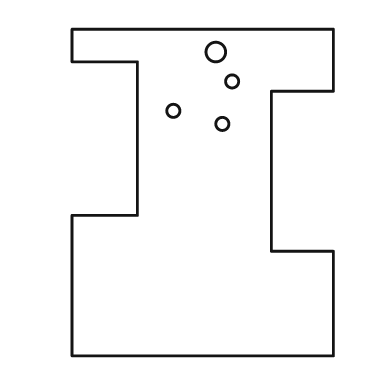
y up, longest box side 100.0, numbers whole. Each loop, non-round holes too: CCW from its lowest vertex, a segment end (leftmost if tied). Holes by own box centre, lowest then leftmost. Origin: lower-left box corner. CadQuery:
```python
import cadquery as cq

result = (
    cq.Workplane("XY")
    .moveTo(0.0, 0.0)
    .lineTo(80.0, 0.0)
    .lineTo(80.0, 32.0)
    .lineTo(61.0, 32.0)
    .lineTo(61.0, 81.0)
    .lineTo(80.0, 81.0)
    .lineTo(80.0, 100.0)
    .lineTo(0.0, 100.0)
    .lineTo(0.0, 90.0)
    .lineTo(20.0, 90.0)
    .lineTo(20.0, 43.0)
    .lineTo(0.0, 43.0)
    .close()
    .moveTo(46.0, 71.0)
    .circle(2.0)
    .moveTo(31.0, 75.0)
    .circle(2.0)
    .moveTo(49.0, 84.0)
    .circle(2.0)
    .moveTo(44.0, 93.0)
    .circle(3.0)
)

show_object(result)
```